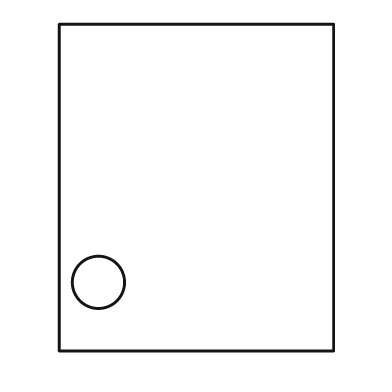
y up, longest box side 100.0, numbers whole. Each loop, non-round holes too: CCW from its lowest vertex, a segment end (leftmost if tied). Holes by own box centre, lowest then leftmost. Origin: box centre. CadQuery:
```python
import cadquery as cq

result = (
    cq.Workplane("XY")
    .moveTo(-42.0, -50.0)
    .lineTo(42.0, -50.0)
    .lineTo(42.0, 50.0)
    .lineTo(-42.0, 50.0)
    .close()
    .moveTo(-30.0, -29.0)
    .circle(8.0)
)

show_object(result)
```